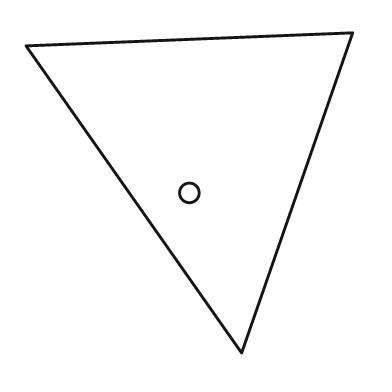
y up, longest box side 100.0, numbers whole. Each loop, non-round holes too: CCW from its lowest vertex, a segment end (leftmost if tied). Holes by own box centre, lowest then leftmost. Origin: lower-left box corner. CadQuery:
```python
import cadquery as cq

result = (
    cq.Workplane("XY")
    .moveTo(66.0, 0.0)
    .lineTo(100.0, 98.0)
    .lineTo(0.0, 94.0)
    .close()
    .moveTo(50.0, 49.0)
    .circle(3.0)
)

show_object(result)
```